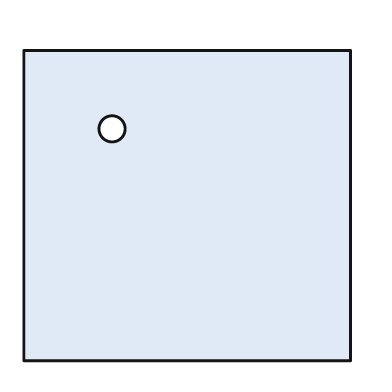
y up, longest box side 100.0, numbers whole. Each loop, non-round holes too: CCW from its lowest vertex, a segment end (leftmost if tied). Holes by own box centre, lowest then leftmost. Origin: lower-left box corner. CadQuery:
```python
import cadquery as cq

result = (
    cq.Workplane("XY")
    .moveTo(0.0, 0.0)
    .lineTo(100.0, 0.0)
    .lineTo(100.0, 95.0)
    .lineTo(0.0, 95.0)
    .close()
    .moveTo(27.0, 71.0)
    .circle(4.0)
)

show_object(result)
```